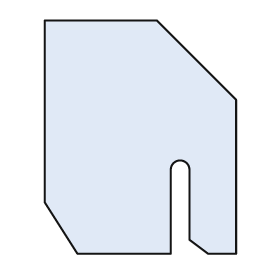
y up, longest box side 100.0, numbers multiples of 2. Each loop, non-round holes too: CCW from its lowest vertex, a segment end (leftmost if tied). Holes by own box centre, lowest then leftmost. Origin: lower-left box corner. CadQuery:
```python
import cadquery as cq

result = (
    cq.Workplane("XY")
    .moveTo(14.0, 0.0)
    .lineTo(54.0, 0.0)
    .lineTo(54.0, 36.0)
    .threePointArc((58.0, 40.0), (62.0, 36.0))
    .lineTo(62.0, 6.0)
    .lineTo(70.0, 0.0)
    .lineTo(82.0, 0.0)
    .lineTo(82.0, 66.0)
    .lineTo(48.0, 100.0)
    .lineTo(0.0, 100.0)
    .lineTo(0.0, 22.0)
    .close()
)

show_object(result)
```